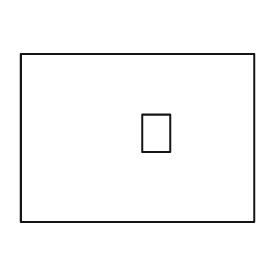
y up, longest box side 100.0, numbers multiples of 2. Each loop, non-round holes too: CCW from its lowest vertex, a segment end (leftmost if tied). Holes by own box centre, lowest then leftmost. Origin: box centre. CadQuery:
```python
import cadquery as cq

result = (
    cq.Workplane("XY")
    .moveTo(-50.0, -36.0)
    .lineTo(50.0, -36.0)
    .lineTo(50.0, 36.0)
    .lineTo(-50.0, 36.0)
    .close()
    .moveTo(2.0, -6.0)
    .lineTo(14.0, -6.0)
    .lineTo(14.0, 10.0)
    .lineTo(2.0, 10.0)
    .close()
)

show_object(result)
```